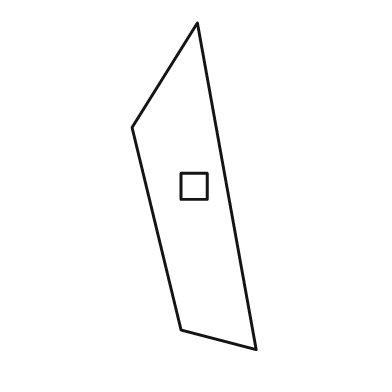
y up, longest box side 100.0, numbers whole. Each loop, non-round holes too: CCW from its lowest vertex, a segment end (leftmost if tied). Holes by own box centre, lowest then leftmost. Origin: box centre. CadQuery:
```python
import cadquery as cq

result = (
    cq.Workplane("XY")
    .moveTo(19.0, -50.0)
    .lineTo(1.0, 50.0)
    .lineTo(-19.0, 18.0)
    .lineTo(-4.0, -44.0)
    .close()
    .moveTo(-4.0, -4.0)
    .lineTo(4.0, -4.0)
    .lineTo(4.0, 4.0)
    .lineTo(-4.0, 4.0)
    .close()
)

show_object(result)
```